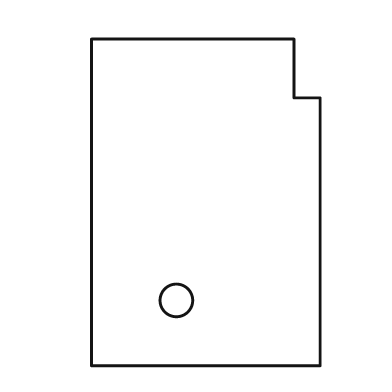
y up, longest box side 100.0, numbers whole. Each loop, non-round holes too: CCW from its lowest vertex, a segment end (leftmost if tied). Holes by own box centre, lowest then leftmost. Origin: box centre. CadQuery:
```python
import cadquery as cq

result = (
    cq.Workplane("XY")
    .moveTo(-35.0, -50.0)
    .lineTo(35.0, -50.0)
    .lineTo(35.0, 32.0)
    .lineTo(27.0, 32.0)
    .lineTo(27.0, 50.0)
    .lineTo(-35.0, 50.0)
    .close()
    .moveTo(-9.0, -30.0)
    .circle(5.0)
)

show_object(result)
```